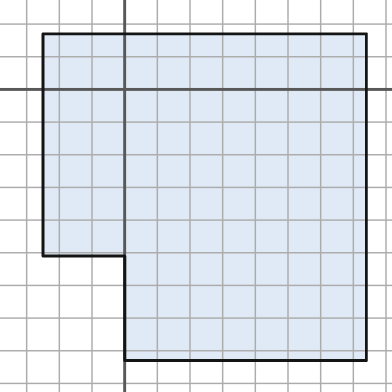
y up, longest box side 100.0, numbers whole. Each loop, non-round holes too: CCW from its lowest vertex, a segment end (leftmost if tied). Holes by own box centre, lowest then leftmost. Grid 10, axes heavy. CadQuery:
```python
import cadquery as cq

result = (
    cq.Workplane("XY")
    .moveTo(0.0, -83.0)
    .lineTo(74.0, -83.0)
    .lineTo(74.0, 17.0)
    .lineTo(-25.0, 17.0)
    .lineTo(-25.0, -51.0)
    .lineTo(0.0, -51.0)
    .close()
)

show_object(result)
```